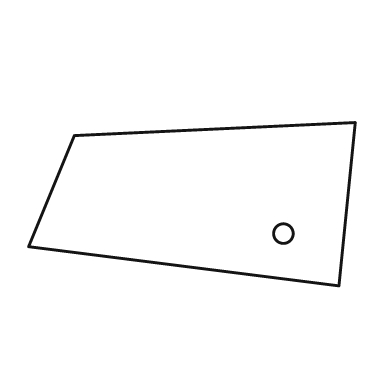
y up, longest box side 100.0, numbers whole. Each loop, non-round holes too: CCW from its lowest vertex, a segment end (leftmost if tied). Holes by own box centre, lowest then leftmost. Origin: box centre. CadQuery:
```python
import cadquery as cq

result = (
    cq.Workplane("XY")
    .moveTo(45.0, -25.0)
    .lineTo(50.0, 25.0)
    .lineTo(-36.0, 21.0)
    .lineTo(-50.0, -13.0)
    .close()
    .moveTo(28.0, -9.0)
    .circle(3.0)
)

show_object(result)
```